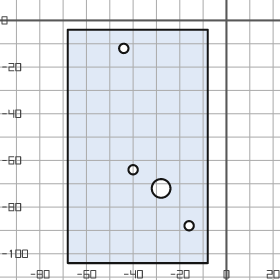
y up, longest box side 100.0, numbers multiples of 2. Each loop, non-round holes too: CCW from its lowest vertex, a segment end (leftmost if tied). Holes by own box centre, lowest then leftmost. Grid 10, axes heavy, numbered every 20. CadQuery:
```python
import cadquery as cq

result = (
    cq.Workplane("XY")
    .moveTo(-68.0, -104.0)
    .lineTo(-8.0, -104.0)
    .lineTo(-8.0, -4.0)
    .lineTo(-68.0, -4.0)
    .close()
    .moveTo(-16.0, -88.0)
    .circle(2.0)
    .moveTo(-28.0, -72.0)
    .circle(4.0)
    .moveTo(-40.0, -64.0)
    .circle(2.0)
    .moveTo(-44.0, -12.0)
    .circle(2.0)
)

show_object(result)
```